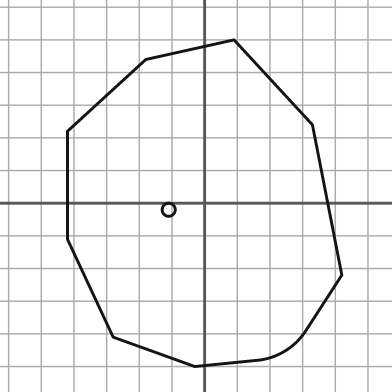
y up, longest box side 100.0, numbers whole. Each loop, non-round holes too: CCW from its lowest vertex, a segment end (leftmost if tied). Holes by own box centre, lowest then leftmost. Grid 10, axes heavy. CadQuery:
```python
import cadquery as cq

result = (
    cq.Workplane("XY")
    .moveTo(-3.0, -50.0)
    .lineTo(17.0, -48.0)
    .threePointArc((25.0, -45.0), (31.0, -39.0))
    .lineTo(42.0, -22.0)
    .lineTo(33.0, 24.0)
    .lineTo(9.0, 50.0)
    .lineTo(-18.0, 44.0)
    .lineTo(-42.0, 22.0)
    .lineTo(-42.0, -11.0)
    .lineTo(-28.0, -41.0)
    .close()
    .moveTo(-11.0, -2.0)
    .circle(2.0)
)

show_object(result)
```